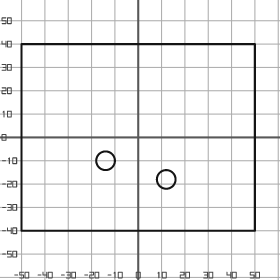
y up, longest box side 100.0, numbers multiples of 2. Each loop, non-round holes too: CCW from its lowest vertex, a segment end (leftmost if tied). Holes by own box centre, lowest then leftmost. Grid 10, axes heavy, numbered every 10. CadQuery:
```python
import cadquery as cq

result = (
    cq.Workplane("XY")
    .moveTo(-50.0, -40.0)
    .lineTo(50.0, -40.0)
    .lineTo(50.0, 40.0)
    .lineTo(-50.0, 40.0)
    .close()
    .moveTo(12.0, -18.0)
    .circle(4.0)
    .moveTo(-14.0, -10.0)
    .circle(4.0)
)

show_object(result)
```